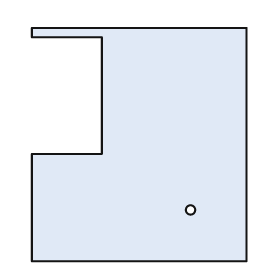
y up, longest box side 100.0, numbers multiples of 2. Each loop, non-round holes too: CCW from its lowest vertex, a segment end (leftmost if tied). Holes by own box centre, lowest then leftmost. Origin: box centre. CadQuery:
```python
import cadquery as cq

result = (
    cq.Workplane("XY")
    .moveTo(-46.0, -50.0)
    .lineTo(46.0, -50.0)
    .lineTo(46.0, 50.0)
    .lineTo(-46.0, 50.0)
    .lineTo(-46.0, 46.0)
    .lineTo(-16.0, 46.0)
    .lineTo(-16.0, -4.0)
    .lineTo(-46.0, -4.0)
    .close()
    .moveTo(22.0, -28.0)
    .circle(2.0)
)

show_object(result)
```